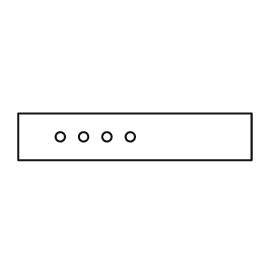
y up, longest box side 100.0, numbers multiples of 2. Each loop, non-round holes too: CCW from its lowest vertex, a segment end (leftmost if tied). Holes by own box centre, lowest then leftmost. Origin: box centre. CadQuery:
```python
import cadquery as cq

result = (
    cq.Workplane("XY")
    .moveTo(-50.0, -10.0)
    .lineTo(50.0, -10.0)
    .lineTo(50.0, 10.0)
    .lineTo(-50.0, 10.0)
    .close()
    .moveTo(-32.0, 0.0)
    .circle(2.0)
    .moveTo(-22.0, 0.0)
    .circle(2.0)
    .moveTo(-12.0, 0.0)
    .circle(2.0)
    .moveTo(-2.0, 0.0)
    .circle(2.0)
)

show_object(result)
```